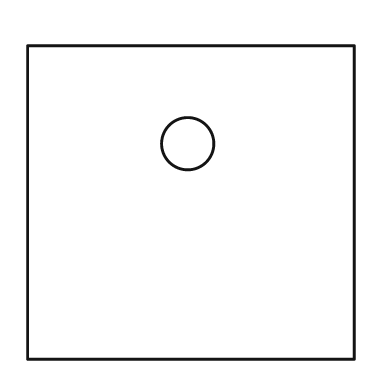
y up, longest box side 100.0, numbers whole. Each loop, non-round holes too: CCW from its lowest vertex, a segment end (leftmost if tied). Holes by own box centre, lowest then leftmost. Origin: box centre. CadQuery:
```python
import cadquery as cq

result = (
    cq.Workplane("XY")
    .moveTo(-50.0, -48.0)
    .lineTo(50.0, -48.0)
    .lineTo(50.0, 48.0)
    .lineTo(-50.0, 48.0)
    .close()
    .moveTo(-1.0, 18.0)
    .circle(8.0)
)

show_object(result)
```